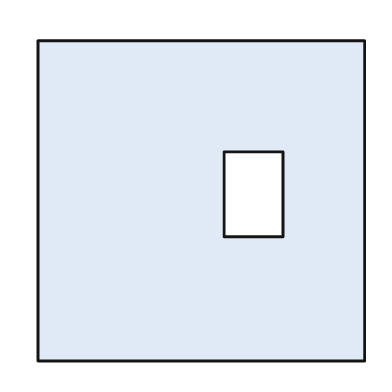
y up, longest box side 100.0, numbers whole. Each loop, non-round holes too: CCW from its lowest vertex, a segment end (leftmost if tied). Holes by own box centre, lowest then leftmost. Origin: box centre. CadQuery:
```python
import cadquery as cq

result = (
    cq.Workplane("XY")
    .moveTo(-50.0, -49.0)
    .lineTo(50.0, -49.0)
    .lineTo(50.0, 49.0)
    .lineTo(-50.0, 49.0)
    .close()
    .moveTo(7.0, -11.0)
    .lineTo(25.0, -11.0)
    .lineTo(25.0, 15.0)
    .lineTo(7.0, 15.0)
    .close()
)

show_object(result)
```